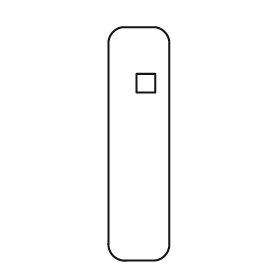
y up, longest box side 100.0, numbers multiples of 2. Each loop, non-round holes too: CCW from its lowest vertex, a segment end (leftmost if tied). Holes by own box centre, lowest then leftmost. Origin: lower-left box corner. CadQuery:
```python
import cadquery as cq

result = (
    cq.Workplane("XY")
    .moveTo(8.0, 0.0)
    .lineTo(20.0, 0.0)
    .threePointArc((24.0, 2.0), (26.0, 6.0))
    .lineTo(26.0, 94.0)
    .threePointArc((24.0, 98.0), (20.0, 100.0))
    .lineTo(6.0, 100.0)
    .threePointArc((2.0, 98.0), (0.0, 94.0))
    .lineTo(0.0, 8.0)
    .threePointArc((2.0, 2.0), (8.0, 0.0))
    .close()
    .moveTo(12.0, 72.0)
    .lineTo(20.0, 72.0)
    .lineTo(20.0, 80.0)
    .lineTo(12.0, 80.0)
    .close()
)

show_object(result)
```